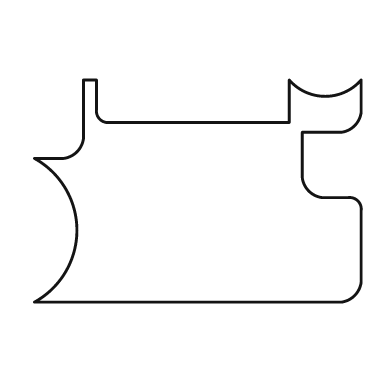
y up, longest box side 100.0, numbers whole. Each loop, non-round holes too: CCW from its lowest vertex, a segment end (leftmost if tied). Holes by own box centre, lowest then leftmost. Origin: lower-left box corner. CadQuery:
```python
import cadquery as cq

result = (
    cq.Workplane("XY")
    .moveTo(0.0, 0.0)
    .lineTo(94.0, 0.0)
    .threePointArc((98.0, 2.0), (100.0, 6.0))
    .lineTo(100.0, 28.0)
    .threePointArc((99.0, 31.0), (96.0, 32.0))
    .lineTo(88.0, 32.0)
    .threePointArc((84.0, 34.0), (82.0, 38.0))
    .lineTo(82.0, 52.0)
    .lineTo(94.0, 52.0)
    .threePointArc((98.0, 54.0), (100.0, 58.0))
    .lineTo(100.0, 68.0)
    .threePointArc((89.0, 63.0), (78.0, 68.0))
    .lineTo(78.0, 55.0)
    .lineTo(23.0, 55.0)
    .threePointArc((20.0, 56.0), (19.0, 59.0))
    .lineTo(19.0, 68.0)
    .lineTo(15.0, 68.0)
    .lineTo(15.0, 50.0)
    .threePointArc((13.0, 46.0), (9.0, 44.0))
    .lineTo(0.0, 44.0)
    .threePointArc((13.0, 22.0), (0.0, 0.0))
    .close()
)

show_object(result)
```